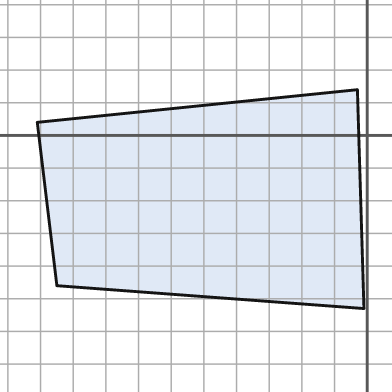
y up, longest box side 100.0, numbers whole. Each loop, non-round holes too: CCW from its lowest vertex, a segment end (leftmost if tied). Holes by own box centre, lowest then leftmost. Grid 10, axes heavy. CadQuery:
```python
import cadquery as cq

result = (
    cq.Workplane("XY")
    .moveTo(-1.0, -53.0)
    .lineTo(-3.0, 14.0)
    .lineTo(-101.0, 4.0)
    .lineTo(-95.0, -46.0)
    .close()
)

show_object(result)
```